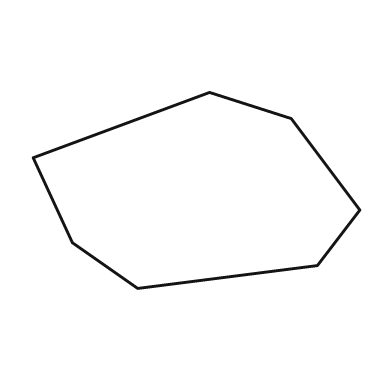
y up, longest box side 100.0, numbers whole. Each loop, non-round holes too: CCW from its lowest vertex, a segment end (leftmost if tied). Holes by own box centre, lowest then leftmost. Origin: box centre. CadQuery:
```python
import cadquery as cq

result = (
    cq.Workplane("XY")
    .moveTo(-18.0, -30.0)
    .lineTo(37.0, -23.0)
    .lineTo(50.0, -6.0)
    .lineTo(29.0, 22.0)
    .lineTo(4.0, 30.0)
    .lineTo(-50.0, 10.0)
    .lineTo(-38.0, -16.0)
    .close()
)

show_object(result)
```